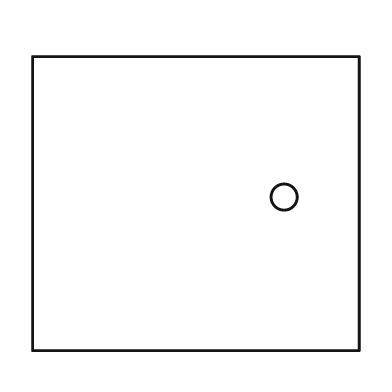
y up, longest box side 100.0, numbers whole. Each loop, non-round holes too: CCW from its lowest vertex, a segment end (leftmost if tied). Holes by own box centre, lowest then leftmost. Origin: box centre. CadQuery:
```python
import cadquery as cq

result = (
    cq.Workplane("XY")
    .moveTo(-50.0, -45.0)
    .lineTo(50.0, -45.0)
    .lineTo(50.0, 45.0)
    .lineTo(-50.0, 45.0)
    .close()
    .moveTo(27.0, 2.0)
    .circle(4.0)
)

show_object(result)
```